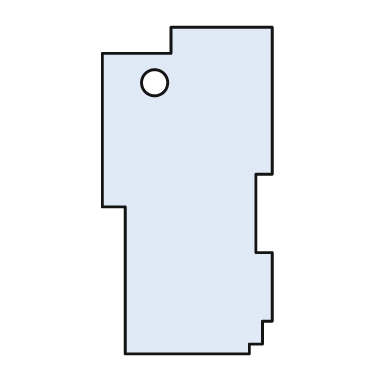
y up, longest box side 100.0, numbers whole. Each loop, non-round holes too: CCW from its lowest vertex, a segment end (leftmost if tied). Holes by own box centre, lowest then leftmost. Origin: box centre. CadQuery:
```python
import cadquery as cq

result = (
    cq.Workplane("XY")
    .moveTo(-19.0, -50.0)
    .lineTo(19.0, -50.0)
    .lineTo(19.0, -47.0)
    .lineTo(23.0, -47.0)
    .lineTo(23.0, -40.0)
    .lineTo(26.0, -40.0)
    .lineTo(26.0, -19.0)
    .lineTo(21.0, -19.0)
    .lineTo(21.0, 5.0)
    .lineTo(26.0, 5.0)
    .lineTo(26.0, 50.0)
    .lineTo(-5.0, 50.0)
    .lineTo(-5.0, 42.0)
    .lineTo(-26.0, 42.0)
    .lineTo(-26.0, -5.0)
    .lineTo(-19.0, -5.0)
    .close()
    .moveTo(-10.0, 33.0)
    .circle(4.0)
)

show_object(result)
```